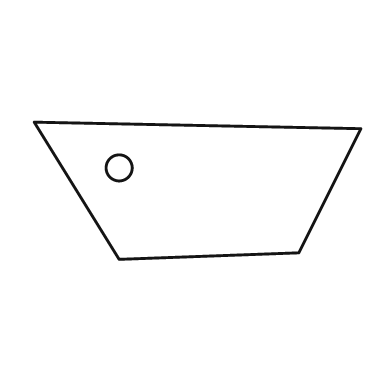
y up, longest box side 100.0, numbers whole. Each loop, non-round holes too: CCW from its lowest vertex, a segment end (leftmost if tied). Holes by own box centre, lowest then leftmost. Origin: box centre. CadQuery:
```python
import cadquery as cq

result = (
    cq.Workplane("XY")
    .moveTo(-24.0, -21.0)
    .lineTo(31.0, -19.0)
    .lineTo(50.0, 19.0)
    .lineTo(-50.0, 21.0)
    .close()
    .moveTo(-24.0, 7.0)
    .circle(4.0)
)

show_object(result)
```